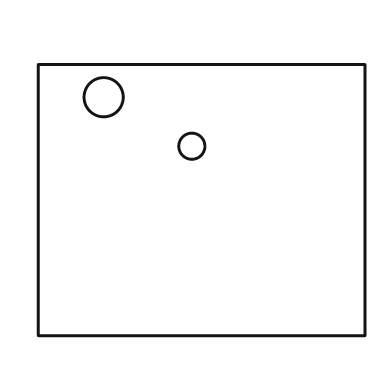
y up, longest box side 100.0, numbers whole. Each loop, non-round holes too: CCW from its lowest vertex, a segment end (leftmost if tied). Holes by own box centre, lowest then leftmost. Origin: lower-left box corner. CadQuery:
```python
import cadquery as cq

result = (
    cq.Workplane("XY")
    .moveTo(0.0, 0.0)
    .lineTo(100.0, 0.0)
    .lineTo(100.0, 83.0)
    .lineTo(0.0, 83.0)
    .close()
    .moveTo(47.0, 58.0)
    .circle(4.0)
    .moveTo(20.0, 73.0)
    .circle(6.0)
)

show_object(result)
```